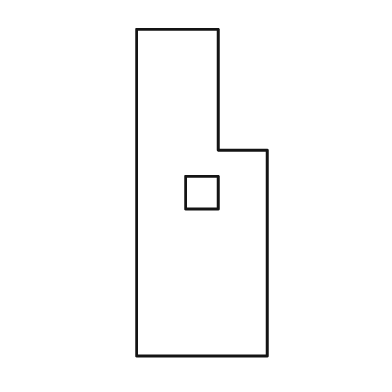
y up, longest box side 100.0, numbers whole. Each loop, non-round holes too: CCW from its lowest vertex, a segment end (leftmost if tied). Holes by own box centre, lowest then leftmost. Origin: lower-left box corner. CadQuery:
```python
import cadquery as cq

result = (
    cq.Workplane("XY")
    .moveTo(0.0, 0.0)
    .lineTo(40.0, 0.0)
    .lineTo(40.0, 63.0)
    .lineTo(25.0, 63.0)
    .lineTo(25.0, 100.0)
    .lineTo(0.0, 100.0)
    .close()
    .moveTo(15.0, 45.0)
    .lineTo(25.0, 45.0)
    .lineTo(25.0, 55.0)
    .lineTo(15.0, 55.0)
    .close()
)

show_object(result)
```